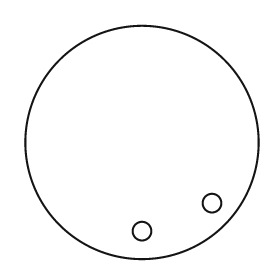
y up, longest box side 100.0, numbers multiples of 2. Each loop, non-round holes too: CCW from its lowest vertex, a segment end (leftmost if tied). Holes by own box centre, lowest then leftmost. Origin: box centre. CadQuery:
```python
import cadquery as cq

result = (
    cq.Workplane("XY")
    .moveTo(0.0, 0.0)
    .circle(50.0)
    .moveTo(0.0, -38.0)
    .circle(4.0)
    .moveTo(30.0, -26.0)
    .circle(4.0)
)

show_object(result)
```